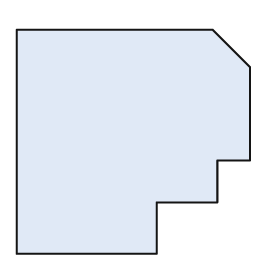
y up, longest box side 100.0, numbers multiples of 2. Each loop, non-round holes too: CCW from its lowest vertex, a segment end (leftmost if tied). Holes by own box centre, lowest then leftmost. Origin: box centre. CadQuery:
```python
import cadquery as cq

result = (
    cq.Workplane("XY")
    .moveTo(-50.0, -48.0)
    .lineTo(10.0, -48.0)
    .lineTo(10.0, -26.0)
    .lineTo(36.0, -26.0)
    .lineTo(36.0, -8.0)
    .lineTo(50.0, -8.0)
    .lineTo(50.0, 32.0)
    .lineTo(34.0, 48.0)
    .lineTo(-50.0, 48.0)
    .close()
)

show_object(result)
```